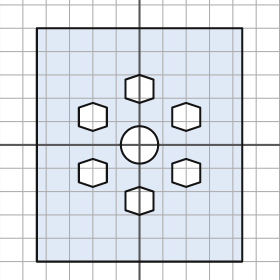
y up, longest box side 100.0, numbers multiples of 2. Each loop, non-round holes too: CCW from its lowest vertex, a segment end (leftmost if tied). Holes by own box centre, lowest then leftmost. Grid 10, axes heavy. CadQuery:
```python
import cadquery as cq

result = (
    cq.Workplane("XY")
    .moveTo(-44.0, -50.0)
    .lineTo(44.0, -50.0)
    .lineTo(44.0, 50.0)
    .lineTo(-44.0, 50.0)
    .close()
    .moveTo(0.0, -30.0)
    .lineTo(6.0, -28.0)
    .lineTo(6.0, -20.0)
    .lineTo(0.0, -18.0)
    .lineTo(-6.0, -20.0)
    .lineTo(-6.0, -28.0)
    .close()
    .moveTo(-20.0, -18.0)
    .lineTo(-14.0, -16.0)
    .lineTo(-14.0, -8.0)
    .lineTo(-20.0, -6.0)
    .lineTo(-26.0, -8.0)
    .lineTo(-26.0, -16.0)
    .close()
    .moveTo(20.0, -18.0)
    .lineTo(26.0, -16.0)
    .lineTo(26.0, -8.0)
    .lineTo(20.0, -6.0)
    .lineTo(14.0, -8.0)
    .lineTo(14.0, -16.0)
    .close()
    .moveTo(0.0, 0.0)
    .circle(8.0)
    .moveTo(-20.0, 6.0)
    .lineTo(-14.0, 8.0)
    .lineTo(-14.0, 16.0)
    .lineTo(-20.0, 18.0)
    .lineTo(-26.0, 16.0)
    .lineTo(-26.0, 8.0)
    .close()
    .moveTo(20.0, 6.0)
    .lineTo(26.0, 8.0)
    .lineTo(26.0, 16.0)
    .lineTo(20.0, 18.0)
    .lineTo(14.0, 16.0)
    .lineTo(14.0, 8.0)
    .close()
    .moveTo(0.0, 18.0)
    .lineTo(6.0, 20.0)
    .lineTo(6.0, 28.0)
    .lineTo(0.0, 30.0)
    .lineTo(-6.0, 28.0)
    .lineTo(-6.0, 20.0)
    .close()
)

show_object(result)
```